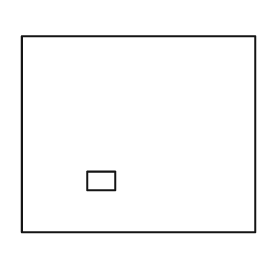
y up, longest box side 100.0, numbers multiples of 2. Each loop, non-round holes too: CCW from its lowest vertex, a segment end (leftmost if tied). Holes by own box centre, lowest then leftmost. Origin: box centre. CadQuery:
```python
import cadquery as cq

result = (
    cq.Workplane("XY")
    .moveTo(-50.0, -42.0)
    .lineTo(50.0, -42.0)
    .lineTo(50.0, 42.0)
    .lineTo(-50.0, 42.0)
    .close()
    .moveTo(-22.0, -24.0)
    .lineTo(-10.0, -24.0)
    .lineTo(-10.0, -16.0)
    .lineTo(-22.0, -16.0)
    .close()
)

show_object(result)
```